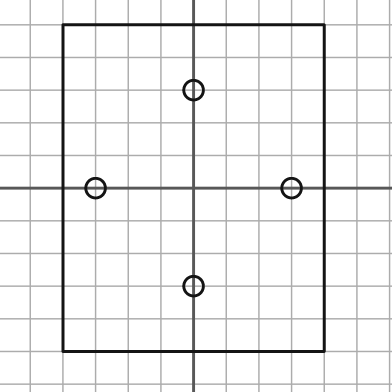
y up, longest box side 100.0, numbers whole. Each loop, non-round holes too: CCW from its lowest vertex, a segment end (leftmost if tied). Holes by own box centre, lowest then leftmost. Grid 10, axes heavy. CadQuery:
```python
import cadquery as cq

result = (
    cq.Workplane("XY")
    .moveTo(-40.0, -50.0)
    .lineTo(40.0, -50.0)
    .lineTo(40.0, 50.0)
    .lineTo(-40.0, 50.0)
    .close()
    .moveTo(0.0, -30.0)
    .circle(3.0)
    .moveTo(-30.0, 0.0)
    .circle(3.0)
    .moveTo(30.0, 0.0)
    .circle(3.0)
    .moveTo(0.0, 30.0)
    .circle(3.0)
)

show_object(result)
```